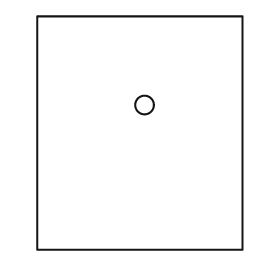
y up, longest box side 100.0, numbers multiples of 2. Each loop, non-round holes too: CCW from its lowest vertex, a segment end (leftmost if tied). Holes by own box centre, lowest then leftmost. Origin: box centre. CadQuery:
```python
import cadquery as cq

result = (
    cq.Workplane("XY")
    .moveTo(-44.0, -50.0)
    .lineTo(44.0, -50.0)
    .lineTo(44.0, 50.0)
    .lineTo(-44.0, 50.0)
    .close()
    .moveTo(2.0, 12.0)
    .circle(4.0)
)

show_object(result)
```